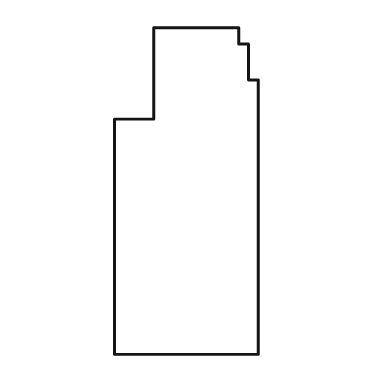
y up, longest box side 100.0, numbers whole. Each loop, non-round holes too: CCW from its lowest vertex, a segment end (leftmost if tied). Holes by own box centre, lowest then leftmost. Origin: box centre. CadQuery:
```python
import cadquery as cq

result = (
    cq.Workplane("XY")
    .moveTo(-22.0, -50.0)
    .lineTo(22.0, -50.0)
    .lineTo(22.0, 34.0)
    .lineTo(19.0, 34.0)
    .lineTo(19.0, 45.0)
    .lineTo(16.0, 45.0)
    .lineTo(16.0, 50.0)
    .lineTo(-10.0, 50.0)
    .lineTo(-10.0, 22.0)
    .lineTo(-22.0, 22.0)
    .close()
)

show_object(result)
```